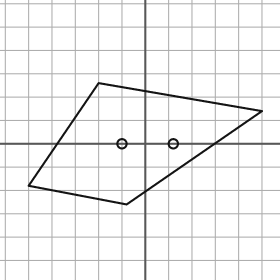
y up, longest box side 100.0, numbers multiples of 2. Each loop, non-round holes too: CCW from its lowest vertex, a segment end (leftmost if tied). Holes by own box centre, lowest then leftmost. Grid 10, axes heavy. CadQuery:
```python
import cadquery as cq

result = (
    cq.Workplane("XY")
    .moveTo(-8.0, -26.0)
    .lineTo(50.0, 14.0)
    .lineTo(-20.0, 26.0)
    .lineTo(-50.0, -18.0)
    .close()
    .moveTo(-10.0, 0.0)
    .circle(2.0)
    .moveTo(12.0, 0.0)
    .circle(2.0)
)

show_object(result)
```